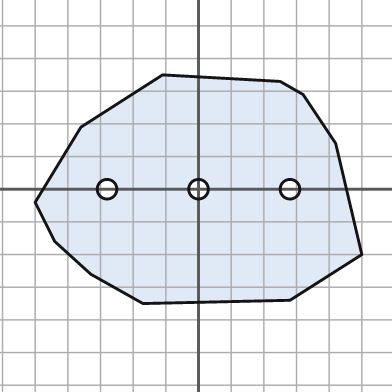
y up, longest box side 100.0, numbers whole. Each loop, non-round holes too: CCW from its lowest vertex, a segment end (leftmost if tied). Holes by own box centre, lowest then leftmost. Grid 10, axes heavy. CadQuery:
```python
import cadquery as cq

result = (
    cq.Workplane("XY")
    .moveTo(-17.0, -35.0)
    .lineTo(28.0, -34.0)
    .lineTo(50.0, -20.0)
    .lineTo(42.0, 14.0)
    .lineTo(32.0, 29.0)
    .lineTo(25.0, 33.0)
    .lineTo(-11.0, 35.0)
    .lineTo(-36.0, 19.0)
    .lineTo(-50.0, -4.0)
    .lineTo(-44.0, -16.0)
    .lineTo(-33.0, -26.0)
    .close()
    .moveTo(-28.0, 0.0)
    .circle(3.0)
    .moveTo(0.0, 0.0)
    .circle(3.0)
    .moveTo(28.0, 0.0)
    .circle(3.0)
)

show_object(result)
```